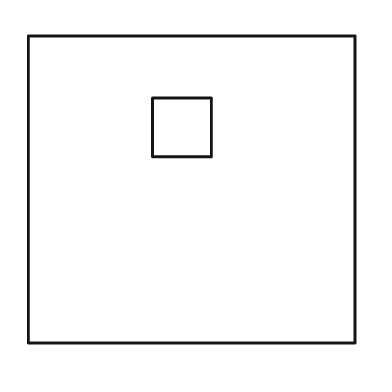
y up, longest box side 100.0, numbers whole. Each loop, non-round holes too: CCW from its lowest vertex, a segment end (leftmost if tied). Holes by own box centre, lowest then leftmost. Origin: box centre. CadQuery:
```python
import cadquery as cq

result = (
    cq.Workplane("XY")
    .moveTo(-50.0, -47.0)
    .lineTo(50.0, -47.0)
    .lineTo(50.0, 47.0)
    .lineTo(-50.0, 47.0)
    .close()
    .moveTo(-12.0, 10.0)
    .lineTo(6.0, 10.0)
    .lineTo(6.0, 28.0)
    .lineTo(-12.0, 28.0)
    .close()
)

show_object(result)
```